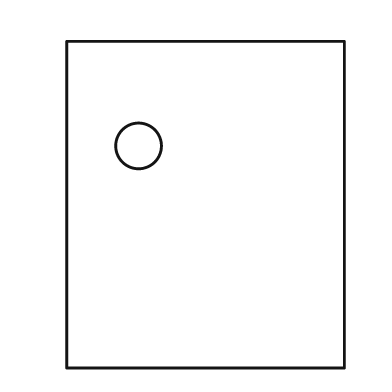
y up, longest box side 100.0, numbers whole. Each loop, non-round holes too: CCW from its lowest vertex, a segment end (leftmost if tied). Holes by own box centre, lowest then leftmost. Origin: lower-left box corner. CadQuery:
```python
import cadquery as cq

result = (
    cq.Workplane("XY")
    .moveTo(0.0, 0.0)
    .lineTo(85.0, 0.0)
    .lineTo(85.0, 100.0)
    .lineTo(0.0, 100.0)
    .close()
    .moveTo(22.0, 68.0)
    .circle(7.0)
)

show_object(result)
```